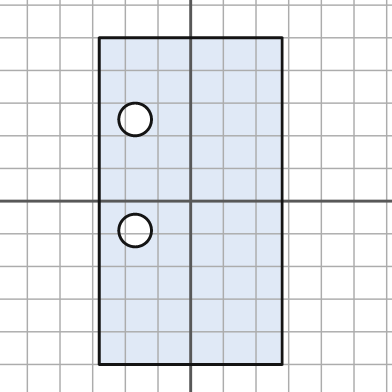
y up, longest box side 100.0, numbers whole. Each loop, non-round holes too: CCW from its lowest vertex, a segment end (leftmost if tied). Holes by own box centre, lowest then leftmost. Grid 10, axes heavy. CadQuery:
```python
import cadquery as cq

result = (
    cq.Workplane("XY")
    .moveTo(-28.0, -50.0)
    .lineTo(28.0, -50.0)
    .lineTo(28.0, 50.0)
    .lineTo(-28.0, 50.0)
    .close()
    .moveTo(-17.0, -9.0)
    .circle(5.0)
    .moveTo(-17.0, 25.0)
    .circle(5.0)
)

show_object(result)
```